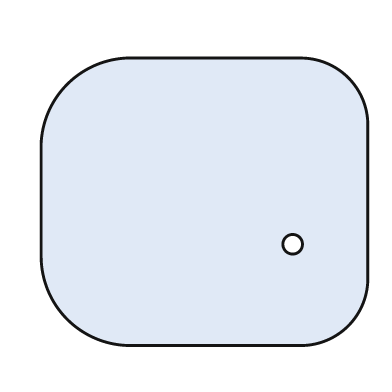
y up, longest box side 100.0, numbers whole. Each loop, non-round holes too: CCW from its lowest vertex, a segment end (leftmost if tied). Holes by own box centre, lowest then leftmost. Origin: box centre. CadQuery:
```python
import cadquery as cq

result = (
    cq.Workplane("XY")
    .moveTo(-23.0, -44.0)
    .lineTo(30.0, -44.0)
    .threePointArc((44.0, -38.0), (50.0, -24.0))
    .lineTo(50.0, 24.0)
    .threePointArc((44.0, 38.0), (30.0, 44.0))
    .lineTo(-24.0, 44.0)
    .threePointArc((-42.0, 36.0), (-50.0, 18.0))
    .lineTo(-50.0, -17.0)
    .threePointArc((-42.0, -36.0), (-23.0, -44.0))
    .close()
    .moveTo(27.0, -13.0)
    .circle(3.0)
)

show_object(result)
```